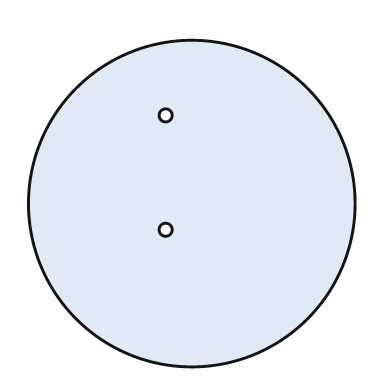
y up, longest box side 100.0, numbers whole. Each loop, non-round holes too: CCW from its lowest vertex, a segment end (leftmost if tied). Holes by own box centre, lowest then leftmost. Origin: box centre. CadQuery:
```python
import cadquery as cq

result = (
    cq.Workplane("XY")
    .moveTo(0.0, 0.0)
    .circle(50.0)
    .moveTo(-8.0, -8.0)
    .circle(2.0)
    .moveTo(-8.0, 27.0)
    .circle(2.0)
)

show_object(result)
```